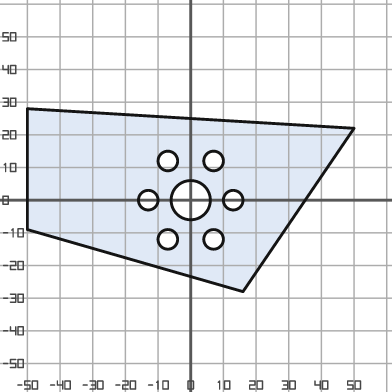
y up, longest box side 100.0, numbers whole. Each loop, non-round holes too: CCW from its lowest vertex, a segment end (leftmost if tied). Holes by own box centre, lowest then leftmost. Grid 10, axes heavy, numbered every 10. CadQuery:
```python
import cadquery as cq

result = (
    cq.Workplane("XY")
    .moveTo(16.0, -28.0)
    .lineTo(50.0, 22.0)
    .lineTo(-50.0, 28.0)
    .lineTo(-50.0, -9.0)
    .close()
    .moveTo(-7.0, -12.0)
    .circle(3.0)
    .moveTo(7.0, -12.0)
    .circle(3.0)
    .moveTo(-13.0, 0.0)
    .circle(3.0)
    .moveTo(0.0, 0.0)
    .circle(6.0)
    .moveTo(13.0, 0.0)
    .circle(3.0)
    .moveTo(-7.0, 12.0)
    .circle(3.0)
    .moveTo(7.0, 12.0)
    .circle(3.0)
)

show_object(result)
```